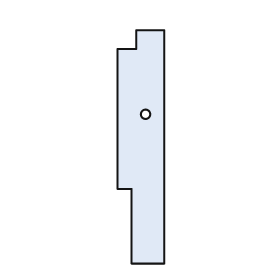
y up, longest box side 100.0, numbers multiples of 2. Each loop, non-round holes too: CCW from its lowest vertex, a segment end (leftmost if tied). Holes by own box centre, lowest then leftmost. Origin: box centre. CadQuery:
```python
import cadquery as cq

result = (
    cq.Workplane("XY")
    .moveTo(-4.0, -50.0)
    .lineTo(10.0, -50.0)
    .lineTo(10.0, 50.0)
    .lineTo(-2.0, 50.0)
    .lineTo(-2.0, 42.0)
    .lineTo(-10.0, 42.0)
    .lineTo(-10.0, -18.0)
    .lineTo(-4.0, -18.0)
    .close()
    .moveTo(2.0, 14.0)
    .circle(2.0)
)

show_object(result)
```